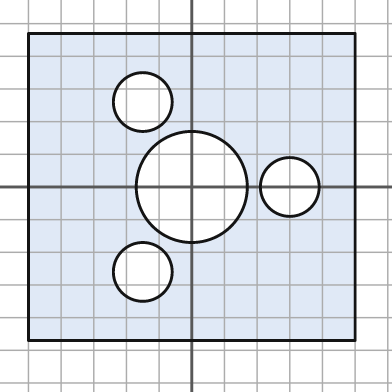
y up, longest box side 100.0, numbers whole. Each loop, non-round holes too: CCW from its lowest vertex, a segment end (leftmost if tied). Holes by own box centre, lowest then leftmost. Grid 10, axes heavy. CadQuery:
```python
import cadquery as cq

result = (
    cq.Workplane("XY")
    .moveTo(-50.0, -47.0)
    .lineTo(50.0, -47.0)
    .lineTo(50.0, 47.0)
    .lineTo(-50.0, 47.0)
    .close()
    .moveTo(-15.0, -26.0)
    .circle(9.0)
    .moveTo(0.0, 0.0)
    .circle(17.0)
    .moveTo(30.0, 0.0)
    .circle(9.0)
    .moveTo(-15.0, 26.0)
    .circle(9.0)
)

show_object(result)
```